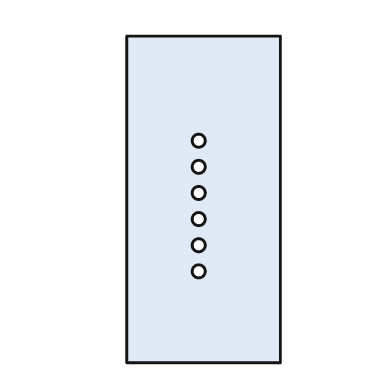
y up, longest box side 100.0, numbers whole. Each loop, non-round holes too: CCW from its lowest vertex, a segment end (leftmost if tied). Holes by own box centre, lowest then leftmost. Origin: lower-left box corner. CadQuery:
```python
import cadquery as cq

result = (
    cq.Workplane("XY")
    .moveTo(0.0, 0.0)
    .lineTo(47.0, 0.0)
    .lineTo(47.0, 100.0)
    .lineTo(0.0, 100.0)
    .close()
    .moveTo(22.0, 28.0)
    .circle(2.0)
    .moveTo(22.0, 36.0)
    .circle(2.0)
    .moveTo(22.0, 44.0)
    .circle(2.0)
    .moveTo(22.0, 52.0)
    .circle(2.0)
    .moveTo(22.0, 60.0)
    .circle(2.0)
    .moveTo(22.0, 68.0)
    .circle(2.0)
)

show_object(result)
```